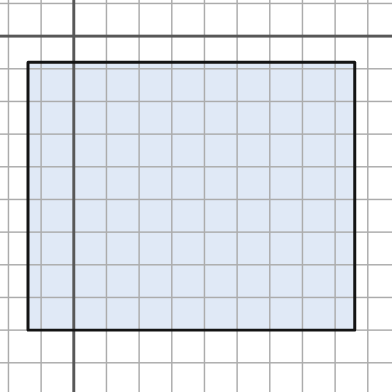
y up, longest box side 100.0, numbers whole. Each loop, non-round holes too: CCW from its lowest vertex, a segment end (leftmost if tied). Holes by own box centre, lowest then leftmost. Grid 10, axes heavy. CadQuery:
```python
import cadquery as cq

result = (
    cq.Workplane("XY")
    .moveTo(-14.0, -90.0)
    .lineTo(86.0, -90.0)
    .lineTo(86.0, -8.0)
    .lineTo(-14.0, -8.0)
    .close()
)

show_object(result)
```